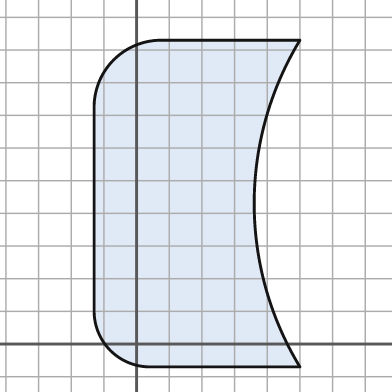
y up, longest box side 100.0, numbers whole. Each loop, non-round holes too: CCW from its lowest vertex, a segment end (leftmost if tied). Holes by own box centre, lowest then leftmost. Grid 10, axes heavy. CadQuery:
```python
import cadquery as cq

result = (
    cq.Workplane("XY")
    .moveTo(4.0, -7.0)
    .lineTo(50.0, -7.0)
    .threePointArc((36.0, 43.0), (50.0, 93.0))
    .lineTo(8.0, 93.0)
    .threePointArc((-7.0, 87.0), (-13.0, 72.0))
    .lineTo(-13.0, 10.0)
    .threePointArc((-8.0, -2.0), (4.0, -7.0))
    .close()
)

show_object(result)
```